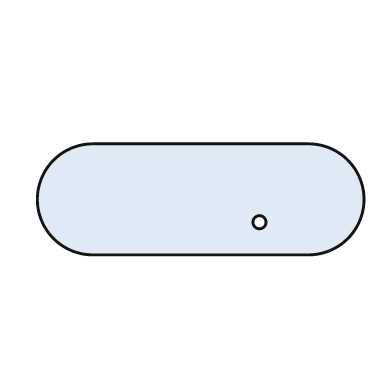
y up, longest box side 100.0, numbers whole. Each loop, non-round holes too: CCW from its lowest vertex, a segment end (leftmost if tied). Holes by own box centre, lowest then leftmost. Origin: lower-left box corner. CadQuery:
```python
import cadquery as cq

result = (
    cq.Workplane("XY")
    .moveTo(17.0, 0.0)
    .lineTo(83.0, 0.0)
    .threePointArc((100.0, 17.0), (83.0, 34.0))
    .lineTo(17.0, 34.0)
    .threePointArc((0.0, 17.0), (17.0, 0.0))
    .close()
    .moveTo(68.0, 10.0)
    .circle(2.0)
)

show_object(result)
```